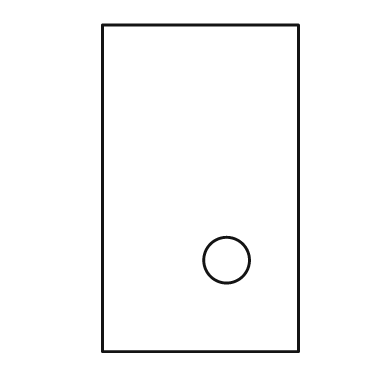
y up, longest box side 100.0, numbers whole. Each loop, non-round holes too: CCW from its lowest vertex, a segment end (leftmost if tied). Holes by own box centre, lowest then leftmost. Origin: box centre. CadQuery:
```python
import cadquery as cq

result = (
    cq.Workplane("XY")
    .moveTo(-30.0, -50.0)
    .lineTo(30.0, -50.0)
    .lineTo(30.0, 50.0)
    .lineTo(-30.0, 50.0)
    .close()
    .moveTo(8.0, -22.0)
    .circle(7.0)
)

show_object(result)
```